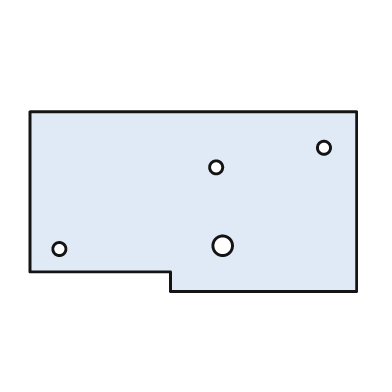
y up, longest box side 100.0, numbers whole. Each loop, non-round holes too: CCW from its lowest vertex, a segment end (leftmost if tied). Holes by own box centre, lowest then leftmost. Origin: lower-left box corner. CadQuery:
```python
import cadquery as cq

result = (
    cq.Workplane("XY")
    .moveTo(43.0, 0.0)
    .lineTo(100.0, 0.0)
    .lineTo(100.0, 55.0)
    .lineTo(0.0, 55.0)
    .lineTo(0.0, 6.0)
    .lineTo(43.0, 6.0)
    .close()
    .moveTo(9.0, 13.0)
    .circle(2.0)
    .moveTo(59.0, 14.0)
    .circle(3.0)
    .moveTo(57.0, 38.0)
    .circle(2.0)
    .moveTo(90.0, 44.0)
    .circle(2.0)
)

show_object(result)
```